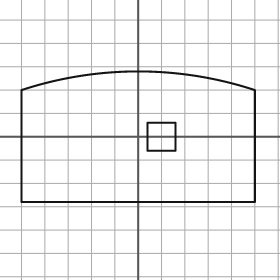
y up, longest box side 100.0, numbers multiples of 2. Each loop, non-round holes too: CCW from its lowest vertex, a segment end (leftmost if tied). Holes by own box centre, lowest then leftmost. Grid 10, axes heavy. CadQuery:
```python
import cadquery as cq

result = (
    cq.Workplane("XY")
    .moveTo(-50.0, -28.0)
    .lineTo(50.0, -28.0)
    .lineTo(50.0, 20.0)
    .threePointArc((0.0, 28.0), (-50.0, 20.0))
    .close()
    .moveTo(4.0, -6.0)
    .lineTo(16.0, -6.0)
    .lineTo(16.0, 6.0)
    .lineTo(4.0, 6.0)
    .close()
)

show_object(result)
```